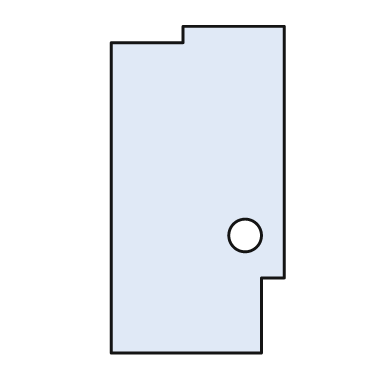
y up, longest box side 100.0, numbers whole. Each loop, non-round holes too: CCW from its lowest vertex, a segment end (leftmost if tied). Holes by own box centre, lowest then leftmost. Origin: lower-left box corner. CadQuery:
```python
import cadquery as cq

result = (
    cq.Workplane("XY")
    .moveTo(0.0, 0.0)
    .lineTo(46.0, 0.0)
    .lineTo(46.0, 23.0)
    .lineTo(53.0, 23.0)
    .lineTo(53.0, 100.0)
    .lineTo(22.0, 100.0)
    .lineTo(22.0, 95.0)
    .lineTo(0.0, 95.0)
    .close()
    .moveTo(41.0, 36.0)
    .circle(5.0)
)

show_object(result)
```